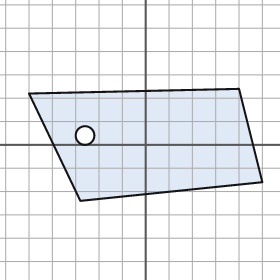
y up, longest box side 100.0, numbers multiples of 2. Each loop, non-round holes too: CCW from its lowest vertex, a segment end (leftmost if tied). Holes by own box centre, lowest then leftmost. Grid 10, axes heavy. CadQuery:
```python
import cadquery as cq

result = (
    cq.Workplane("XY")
    .moveTo(-28.0, -24.0)
    .lineTo(50.0, -16.0)
    .lineTo(40.0, 24.0)
    .lineTo(-50.0, 22.0)
    .close()
    .moveTo(-26.0, 4.0)
    .circle(4.0)
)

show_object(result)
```